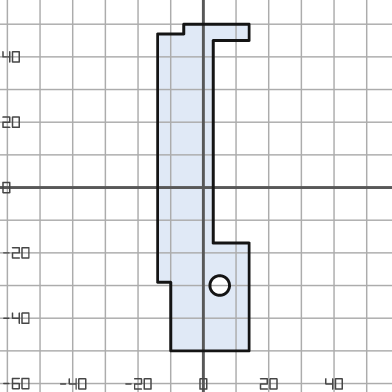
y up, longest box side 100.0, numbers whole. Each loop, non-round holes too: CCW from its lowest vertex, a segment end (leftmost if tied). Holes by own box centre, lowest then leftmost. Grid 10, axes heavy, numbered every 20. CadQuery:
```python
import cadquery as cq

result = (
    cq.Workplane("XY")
    .moveTo(-10.0, -50.0)
    .lineTo(14.0, -50.0)
    .lineTo(14.0, -17.0)
    .lineTo(3.0, -17.0)
    .lineTo(3.0, 45.0)
    .lineTo(14.0, 45.0)
    .lineTo(14.0, 50.0)
    .lineTo(-6.0, 50.0)
    .lineTo(-6.0, 47.0)
    .lineTo(-14.0, 47.0)
    .lineTo(-14.0, -29.0)
    .lineTo(-10.0, -29.0)
    .close()
    .moveTo(5.0, -30.0)
    .circle(3.0)
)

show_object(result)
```